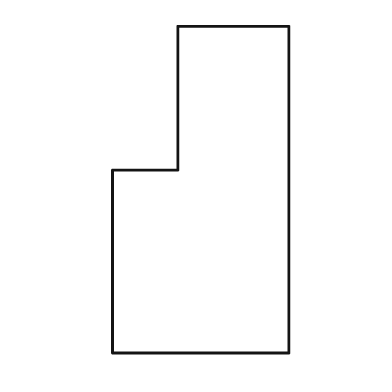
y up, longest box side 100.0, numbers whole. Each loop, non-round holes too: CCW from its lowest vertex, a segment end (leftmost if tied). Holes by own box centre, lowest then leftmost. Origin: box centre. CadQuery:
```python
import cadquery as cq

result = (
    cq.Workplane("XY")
    .moveTo(-27.0, -50.0)
    .lineTo(27.0, -50.0)
    .lineTo(27.0, 50.0)
    .lineTo(-7.0, 50.0)
    .lineTo(-7.0, 6.0)
    .lineTo(-27.0, 6.0)
    .close()
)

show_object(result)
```